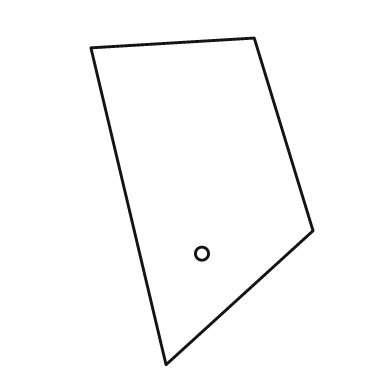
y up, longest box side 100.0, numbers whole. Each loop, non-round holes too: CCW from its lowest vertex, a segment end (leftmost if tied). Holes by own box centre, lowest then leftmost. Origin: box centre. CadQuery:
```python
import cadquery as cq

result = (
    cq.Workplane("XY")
    .moveTo(-11.0, -50.0)
    .lineTo(34.0, -9.0)
    .lineTo(16.0, 50.0)
    .lineTo(-34.0, 47.0)
    .close()
    .moveTo(0.0, -16.0)
    .circle(2.0)
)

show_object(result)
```